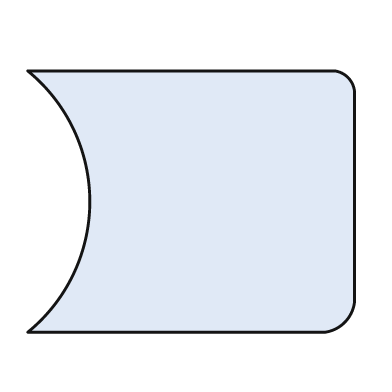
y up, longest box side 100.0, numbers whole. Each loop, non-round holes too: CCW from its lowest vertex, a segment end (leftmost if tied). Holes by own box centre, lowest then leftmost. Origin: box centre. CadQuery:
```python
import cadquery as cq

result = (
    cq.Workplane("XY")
    .moveTo(-50.0, -40.0)
    .lineTo(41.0, -40.0)
    .threePointArc((47.0, -37.0), (50.0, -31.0))
    .lineTo(50.0, 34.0)
    .threePointArc((48.0, 38.0), (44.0, 40.0))
    .lineTo(-50.0, 40.0)
    .threePointArc((-31.0, 0.0), (-50.0, -40.0))
    .close()
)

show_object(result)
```